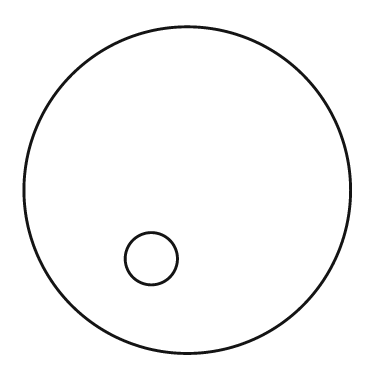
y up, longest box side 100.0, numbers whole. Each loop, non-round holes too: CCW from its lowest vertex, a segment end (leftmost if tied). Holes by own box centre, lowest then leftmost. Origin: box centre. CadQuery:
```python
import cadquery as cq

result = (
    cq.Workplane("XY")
    .moveTo(0.0, 0.0)
    .circle(50.0)
    .moveTo(-11.0, -21.0)
    .circle(8.0)
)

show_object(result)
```